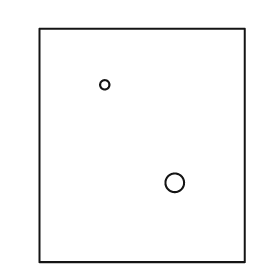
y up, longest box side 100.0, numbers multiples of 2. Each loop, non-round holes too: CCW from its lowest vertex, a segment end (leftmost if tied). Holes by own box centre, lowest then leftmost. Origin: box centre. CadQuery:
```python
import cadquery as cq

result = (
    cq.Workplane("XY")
    .moveTo(-44.0, -50.0)
    .lineTo(44.0, -50.0)
    .lineTo(44.0, 50.0)
    .lineTo(-44.0, 50.0)
    .close()
    .moveTo(14.0, -16.0)
    .circle(4.0)
    .moveTo(-16.0, 26.0)
    .circle(2.0)
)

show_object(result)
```